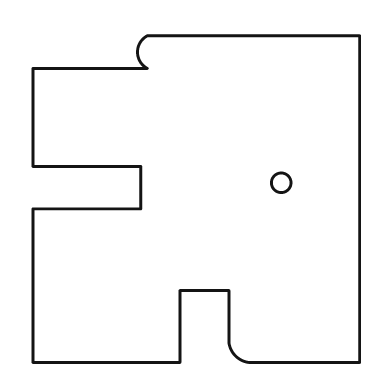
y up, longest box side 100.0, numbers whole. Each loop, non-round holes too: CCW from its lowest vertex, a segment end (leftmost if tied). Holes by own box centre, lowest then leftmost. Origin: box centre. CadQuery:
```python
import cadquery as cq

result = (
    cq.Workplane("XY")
    .moveTo(-50.0, -50.0)
    .lineTo(-5.0, -50.0)
    .lineTo(-5.0, -28.0)
    .lineTo(10.0, -28.0)
    .lineTo(10.0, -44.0)
    .threePointArc((12.0, -48.0), (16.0, -50.0))
    .lineTo(50.0, -50.0)
    .lineTo(50.0, 50.0)
    .lineTo(-15.0, 50.0)
    .threePointArc((-18.0, 45.0), (-15.0, 40.0))
    .lineTo(-50.0, 40.0)
    .lineTo(-50.0, 10.0)
    .lineTo(-17.0, 10.0)
    .lineTo(-17.0, -3.0)
    .lineTo(-50.0, -3.0)
    .close()
    .moveTo(26.0, 5.0)
    .circle(3.0)
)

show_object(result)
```